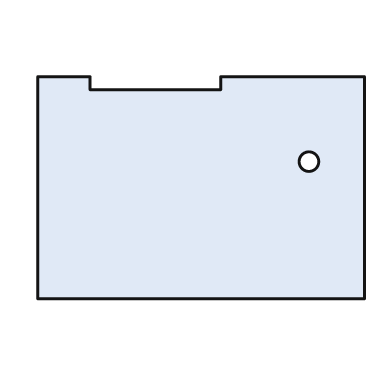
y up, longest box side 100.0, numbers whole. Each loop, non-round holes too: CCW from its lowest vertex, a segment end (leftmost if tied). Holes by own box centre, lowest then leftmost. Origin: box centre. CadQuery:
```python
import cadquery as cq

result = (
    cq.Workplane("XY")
    .moveTo(-50.0, -34.0)
    .lineTo(50.0, -34.0)
    .lineTo(50.0, 34.0)
    .lineTo(6.0, 34.0)
    .lineTo(6.0, 30.0)
    .lineTo(-34.0, 30.0)
    .lineTo(-34.0, 34.0)
    .lineTo(-50.0, 34.0)
    .close()
    .moveTo(33.0, 8.0)
    .circle(3.0)
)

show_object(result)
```